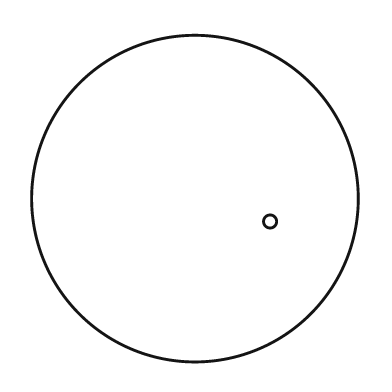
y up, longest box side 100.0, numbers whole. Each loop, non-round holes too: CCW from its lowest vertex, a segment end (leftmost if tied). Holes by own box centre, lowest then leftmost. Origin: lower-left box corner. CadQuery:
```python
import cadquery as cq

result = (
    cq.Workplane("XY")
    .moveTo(50.0, 50.0)
    .circle(50.0)
    .moveTo(73.0, 43.0)
    .circle(2.0)
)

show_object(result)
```